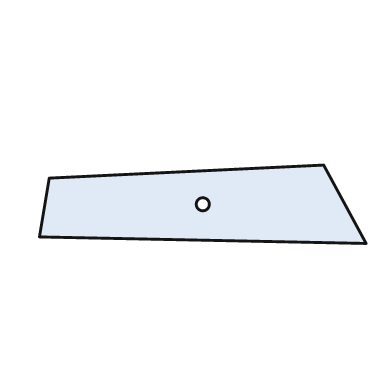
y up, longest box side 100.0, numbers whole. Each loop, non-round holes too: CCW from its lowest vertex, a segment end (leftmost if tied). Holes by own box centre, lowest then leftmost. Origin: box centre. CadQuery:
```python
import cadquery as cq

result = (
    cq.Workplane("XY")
    .moveTo(50.0, -12.0)
    .lineTo(37.0, 12.0)
    .lineTo(-47.0, 8.0)
    .lineTo(-50.0, -10.0)
    .close()
    .moveTo(0.0, 0.0)
    .circle(2.0)
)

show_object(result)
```